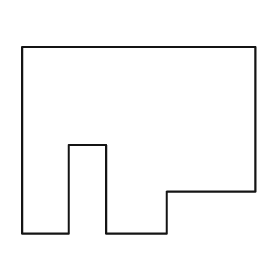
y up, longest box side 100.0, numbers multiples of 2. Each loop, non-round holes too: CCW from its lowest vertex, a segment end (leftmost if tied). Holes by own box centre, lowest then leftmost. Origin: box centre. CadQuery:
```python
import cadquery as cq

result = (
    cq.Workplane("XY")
    .moveTo(-50.0, -40.0)
    .lineTo(-30.0, -40.0)
    .lineTo(-30.0, -2.0)
    .lineTo(-14.0, -2.0)
    .lineTo(-14.0, -40.0)
    .lineTo(12.0, -40.0)
    .lineTo(12.0, -22.0)
    .lineTo(50.0, -22.0)
    .lineTo(50.0, 40.0)
    .lineTo(-50.0, 40.0)
    .close()
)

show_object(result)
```